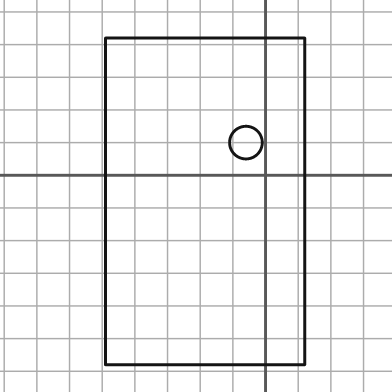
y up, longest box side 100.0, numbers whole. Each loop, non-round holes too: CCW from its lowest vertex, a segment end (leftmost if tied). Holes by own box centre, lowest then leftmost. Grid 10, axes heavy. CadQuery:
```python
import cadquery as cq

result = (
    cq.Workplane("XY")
    .moveTo(-49.0, -58.0)
    .lineTo(12.0, -58.0)
    .lineTo(12.0, 42.0)
    .lineTo(-49.0, 42.0)
    .close()
    .moveTo(-6.0, 10.0)
    .circle(5.0)
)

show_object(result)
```